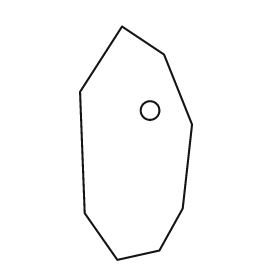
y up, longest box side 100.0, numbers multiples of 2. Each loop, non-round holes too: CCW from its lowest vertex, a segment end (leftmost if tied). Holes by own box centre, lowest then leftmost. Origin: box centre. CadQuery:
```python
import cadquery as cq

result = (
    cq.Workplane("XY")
    .moveTo(-8.0, -50.0)
    .lineTo(10.0, -46.0)
    .lineTo(20.0, -28.0)
    .lineTo(24.0, 8.0)
    .lineTo(12.0, 38.0)
    .lineTo(-6.0, 50.0)
    .lineTo(-24.0, 22.0)
    .lineTo(-22.0, -30.0)
    .close()
    .moveTo(6.0, 14.0)
    .circle(4.0)
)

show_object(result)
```